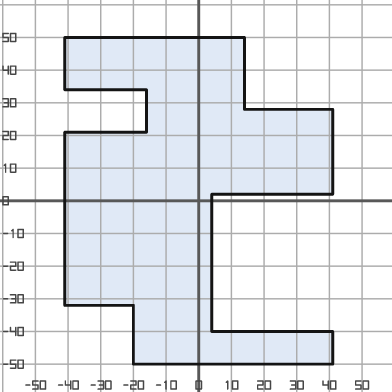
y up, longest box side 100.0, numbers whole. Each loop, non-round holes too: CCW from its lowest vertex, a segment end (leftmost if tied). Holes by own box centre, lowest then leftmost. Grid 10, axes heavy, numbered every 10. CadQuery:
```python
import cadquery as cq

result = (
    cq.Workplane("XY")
    .moveTo(-20.0, -50.0)
    .lineTo(41.0, -50.0)
    .lineTo(41.0, -40.0)
    .lineTo(4.0, -40.0)
    .lineTo(4.0, 2.0)
    .lineTo(41.0, 2.0)
    .lineTo(41.0, 28.0)
    .lineTo(14.0, 28.0)
    .lineTo(14.0, 50.0)
    .lineTo(-41.0, 50.0)
    .lineTo(-41.0, 34.0)
    .lineTo(-16.0, 34.0)
    .lineTo(-16.0, 21.0)
    .lineTo(-41.0, 21.0)
    .lineTo(-41.0, -32.0)
    .lineTo(-20.0, -32.0)
    .close()
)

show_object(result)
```